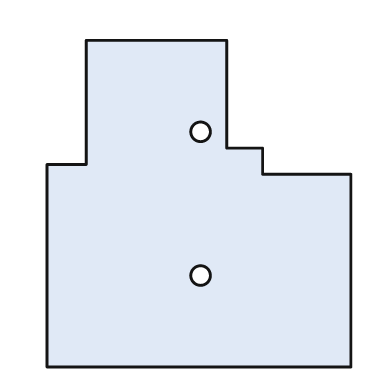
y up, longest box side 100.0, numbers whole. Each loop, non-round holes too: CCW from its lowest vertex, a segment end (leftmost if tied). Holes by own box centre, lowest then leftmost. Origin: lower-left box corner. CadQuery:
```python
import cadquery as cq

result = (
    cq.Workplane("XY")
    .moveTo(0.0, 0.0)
    .lineTo(93.0, 0.0)
    .lineTo(93.0, 59.0)
    .lineTo(66.0, 59.0)
    .lineTo(66.0, 67.0)
    .lineTo(55.0, 67.0)
    .lineTo(55.0, 100.0)
    .lineTo(12.0, 100.0)
    .lineTo(12.0, 62.0)
    .lineTo(0.0, 62.0)
    .close()
    .moveTo(47.0, 28.0)
    .circle(3.0)
    .moveTo(47.0, 72.0)
    .circle(3.0)
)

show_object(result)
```